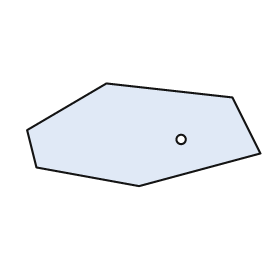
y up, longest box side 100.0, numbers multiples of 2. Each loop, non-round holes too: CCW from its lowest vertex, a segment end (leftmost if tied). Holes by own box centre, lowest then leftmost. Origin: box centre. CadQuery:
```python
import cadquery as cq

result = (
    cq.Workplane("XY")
    .moveTo(-2.0, -22.0)
    .lineTo(50.0, -8.0)
    .lineTo(38.0, 16.0)
    .lineTo(-16.0, 22.0)
    .lineTo(-50.0, 2.0)
    .lineTo(-46.0, -14.0)
    .close()
    .moveTo(16.0, -2.0)
    .circle(2.0)
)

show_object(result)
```